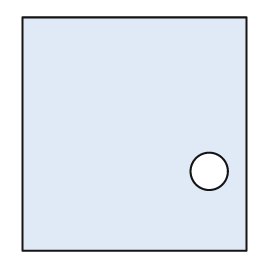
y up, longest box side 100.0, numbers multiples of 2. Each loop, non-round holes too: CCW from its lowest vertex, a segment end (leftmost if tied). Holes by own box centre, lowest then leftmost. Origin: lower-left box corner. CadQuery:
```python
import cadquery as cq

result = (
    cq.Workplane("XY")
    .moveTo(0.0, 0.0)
    .lineTo(96.0, 0.0)
    .lineTo(96.0, 100.0)
    .lineTo(0.0, 100.0)
    .close()
    .moveTo(80.0, 34.0)
    .circle(8.0)
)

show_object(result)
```